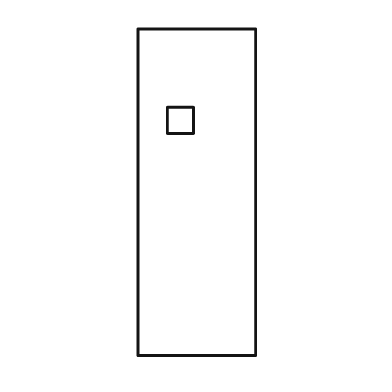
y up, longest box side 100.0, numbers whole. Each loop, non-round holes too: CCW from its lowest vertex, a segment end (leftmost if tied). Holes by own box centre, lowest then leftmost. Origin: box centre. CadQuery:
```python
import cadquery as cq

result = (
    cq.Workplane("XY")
    .moveTo(-18.0, -50.0)
    .lineTo(18.0, -50.0)
    .lineTo(18.0, 50.0)
    .lineTo(-18.0, 50.0)
    .close()
    .moveTo(-9.0, 18.0)
    .lineTo(-1.0, 18.0)
    .lineTo(-1.0, 26.0)
    .lineTo(-9.0, 26.0)
    .close()
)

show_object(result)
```